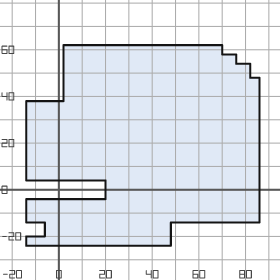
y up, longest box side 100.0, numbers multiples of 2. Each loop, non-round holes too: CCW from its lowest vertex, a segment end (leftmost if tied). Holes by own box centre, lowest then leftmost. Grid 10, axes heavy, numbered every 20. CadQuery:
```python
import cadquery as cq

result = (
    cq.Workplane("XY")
    .moveTo(-14.0, -24.0)
    .lineTo(48.0, -24.0)
    .lineTo(48.0, -14.0)
    .lineTo(86.0, -14.0)
    .lineTo(86.0, 48.0)
    .lineTo(82.0, 48.0)
    .lineTo(82.0, 54.0)
    .lineTo(76.0, 54.0)
    .lineTo(76.0, 58.0)
    .lineTo(70.0, 58.0)
    .lineTo(70.0, 62.0)
    .lineTo(2.0, 62.0)
    .lineTo(2.0, 38.0)
    .lineTo(-14.0, 38.0)
    .lineTo(-14.0, 4.0)
    .lineTo(20.0, 4.0)
    .lineTo(20.0, -4.0)
    .lineTo(-14.0, -4.0)
    .lineTo(-14.0, -14.0)
    .lineTo(-6.0, -14.0)
    .lineTo(-6.0, -20.0)
    .lineTo(-14.0, -20.0)
    .close()
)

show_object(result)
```